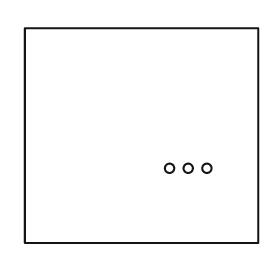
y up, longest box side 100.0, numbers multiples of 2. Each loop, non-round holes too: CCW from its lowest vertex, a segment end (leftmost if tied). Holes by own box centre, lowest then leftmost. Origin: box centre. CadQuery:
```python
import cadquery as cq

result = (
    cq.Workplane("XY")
    .moveTo(-50.0, -46.0)
    .lineTo(50.0, -46.0)
    .lineTo(50.0, 46.0)
    .lineTo(-50.0, 46.0)
    .close()
    .moveTo(12.0, -14.0)
    .circle(2.0)
    .moveTo(20.0, -14.0)
    .circle(2.0)
    .moveTo(28.0, -14.0)
    .circle(2.0)
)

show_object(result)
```